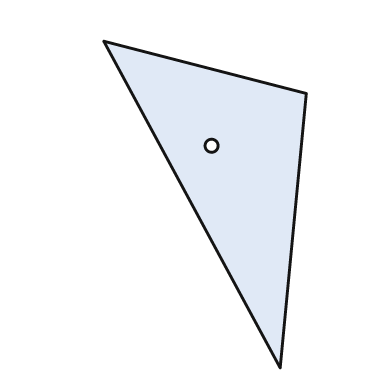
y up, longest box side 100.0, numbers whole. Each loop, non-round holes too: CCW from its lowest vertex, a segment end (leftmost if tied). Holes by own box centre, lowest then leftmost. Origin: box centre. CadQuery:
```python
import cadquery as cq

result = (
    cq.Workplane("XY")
    .moveTo(23.0, -50.0)
    .lineTo(31.0, 34.0)
    .lineTo(-31.0, 50.0)
    .close()
    .moveTo(2.0, 18.0)
    .circle(2.0)
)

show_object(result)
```